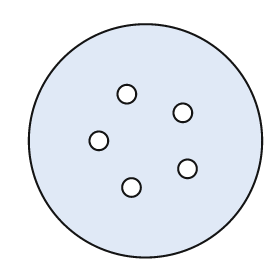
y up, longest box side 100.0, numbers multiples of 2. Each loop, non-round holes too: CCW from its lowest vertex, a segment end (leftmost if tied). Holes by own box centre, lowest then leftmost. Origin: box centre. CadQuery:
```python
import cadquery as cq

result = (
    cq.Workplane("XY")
    .moveTo(0.0, 0.0)
    .circle(50.0)
    .moveTo(-6.0, -20.0)
    .circle(4.0)
    .moveTo(18.0, -12.0)
    .circle(4.0)
    .moveTo(-20.0, 0.0)
    .circle(4.0)
    .moveTo(16.0, 12.0)
    .circle(4.0)
    .moveTo(-8.0, 20.0)
    .circle(4.0)
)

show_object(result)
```